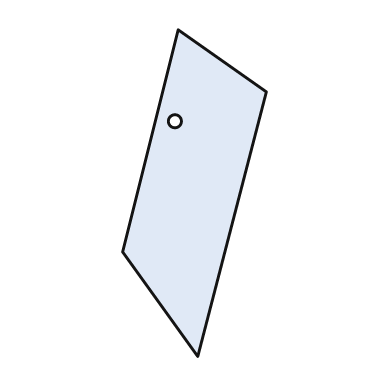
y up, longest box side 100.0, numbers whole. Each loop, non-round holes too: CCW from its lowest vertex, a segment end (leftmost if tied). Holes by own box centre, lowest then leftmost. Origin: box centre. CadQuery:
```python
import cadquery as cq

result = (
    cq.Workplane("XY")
    .moveTo(1.0, -50.0)
    .lineTo(22.0, 31.0)
    .lineTo(-5.0, 50.0)
    .lineTo(-22.0, -18.0)
    .close()
    .moveTo(-6.0, 22.0)
    .circle(2.0)
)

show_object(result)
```